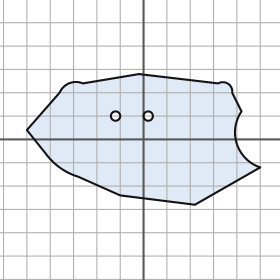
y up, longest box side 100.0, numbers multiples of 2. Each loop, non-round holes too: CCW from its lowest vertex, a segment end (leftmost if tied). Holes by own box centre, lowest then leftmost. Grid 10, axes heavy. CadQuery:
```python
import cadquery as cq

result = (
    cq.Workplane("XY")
    .moveTo(22.0, -28.0)
    .lineTo(50.0, -12.0)
    .threePointArc((40.0, -2.0), (42.0, 12.0))
    .lineTo(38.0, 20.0)
    .threePointArc((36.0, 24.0), (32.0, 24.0))
    .lineTo(-2.0, 28.0)
    .lineTo(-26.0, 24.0)
    .threePointArc((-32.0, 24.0), (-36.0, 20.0))
    .lineTo(-50.0, 4.0)
    .lineTo(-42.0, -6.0)
    .threePointArc((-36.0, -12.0), (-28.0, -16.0))
    .lineTo(-10.0, -24.0)
    .close()
    .moveTo(-12.0, 10.0)
    .circle(2.0)
    .moveTo(2.0, 10.0)
    .circle(2.0)
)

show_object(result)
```